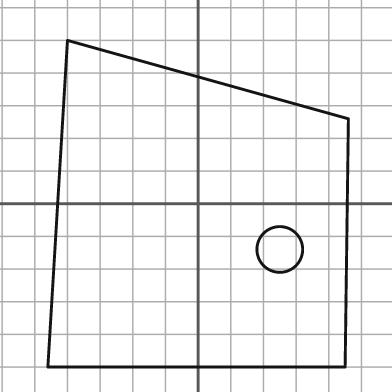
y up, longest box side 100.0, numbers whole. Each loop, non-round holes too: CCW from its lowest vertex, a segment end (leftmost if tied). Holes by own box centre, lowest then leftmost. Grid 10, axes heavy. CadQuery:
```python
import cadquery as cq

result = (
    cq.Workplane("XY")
    .moveTo(-46.0, -50.0)
    .lineTo(45.0, -50.0)
    .lineTo(46.0, 26.0)
    .lineTo(-40.0, 50.0)
    .close()
    .moveTo(25.0, -14.0)
    .circle(7.0)
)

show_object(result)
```